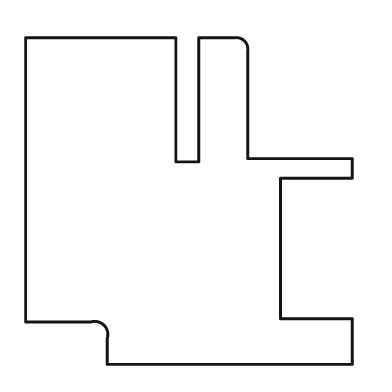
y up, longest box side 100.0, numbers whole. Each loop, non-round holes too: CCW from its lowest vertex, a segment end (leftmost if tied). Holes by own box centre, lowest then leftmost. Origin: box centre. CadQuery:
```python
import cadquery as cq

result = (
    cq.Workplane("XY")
    .moveTo(-25.0, -50.0)
    .lineTo(50.0, -50.0)
    .lineTo(50.0, -36.0)
    .lineTo(28.0, -36.0)
    .lineTo(28.0, 7.0)
    .lineTo(50.0, 7.0)
    .lineTo(50.0, 13.0)
    .lineTo(18.0, 13.0)
    .lineTo(18.0, 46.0)
    .threePointArc((17.0, 49.0), (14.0, 50.0))
    .lineTo(3.0, 50.0)
    .lineTo(3.0, 12.0)
    .lineTo(-4.0, 12.0)
    .lineTo(-4.0, 50.0)
    .lineTo(-50.0, 50.0)
    .lineTo(-50.0, -37.0)
    .lineTo(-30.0, -37.0)
    .threePointArc((-26.0, -38.0), (-25.0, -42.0))
    .close()
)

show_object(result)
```